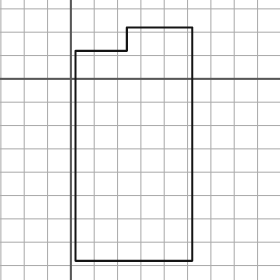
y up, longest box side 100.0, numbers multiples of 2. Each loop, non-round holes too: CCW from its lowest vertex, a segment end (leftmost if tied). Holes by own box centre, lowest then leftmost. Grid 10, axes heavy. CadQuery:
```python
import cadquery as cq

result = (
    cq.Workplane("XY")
    .moveTo(2.0, -78.0)
    .lineTo(52.0, -78.0)
    .lineTo(52.0, 22.0)
    .lineTo(24.0, 22.0)
    .lineTo(24.0, 12.0)
    .lineTo(2.0, 12.0)
    .close()
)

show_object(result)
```